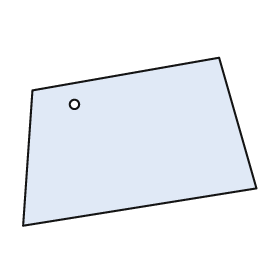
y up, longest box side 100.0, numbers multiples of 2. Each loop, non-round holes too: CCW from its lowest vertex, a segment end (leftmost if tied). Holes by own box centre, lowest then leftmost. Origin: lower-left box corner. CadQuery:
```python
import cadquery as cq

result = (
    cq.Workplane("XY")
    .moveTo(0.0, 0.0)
    .lineTo(100.0, 16.0)
    .lineTo(84.0, 72.0)
    .lineTo(4.0, 58.0)
    .close()
    .moveTo(22.0, 52.0)
    .circle(2.0)
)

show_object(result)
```